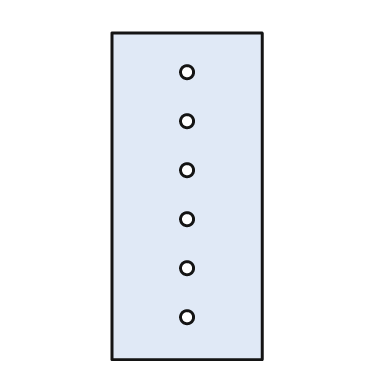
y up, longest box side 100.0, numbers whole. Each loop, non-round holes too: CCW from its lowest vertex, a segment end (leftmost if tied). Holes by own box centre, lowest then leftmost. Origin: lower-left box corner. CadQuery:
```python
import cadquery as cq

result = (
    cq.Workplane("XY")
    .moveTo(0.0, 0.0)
    .lineTo(46.0, 0.0)
    .lineTo(46.0, 100.0)
    .lineTo(0.0, 100.0)
    .close()
    .moveTo(23.0, 13.0)
    .circle(2.0)
    .moveTo(23.0, 28.0)
    .circle(2.0)
    .moveTo(23.0, 43.0)
    .circle(2.0)
    .moveTo(23.0, 58.0)
    .circle(2.0)
    .moveTo(23.0, 73.0)
    .circle(2.0)
    .moveTo(23.0, 88.0)
    .circle(2.0)
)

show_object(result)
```